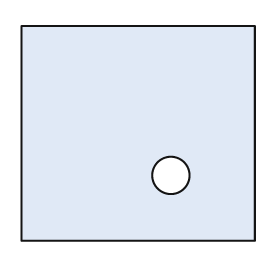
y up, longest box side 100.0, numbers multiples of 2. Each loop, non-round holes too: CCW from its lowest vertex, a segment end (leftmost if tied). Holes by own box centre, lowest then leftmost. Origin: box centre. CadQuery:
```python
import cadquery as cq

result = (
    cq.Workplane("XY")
    .moveTo(-50.0, -46.0)
    .lineTo(50.0, -46.0)
    .lineTo(50.0, 46.0)
    .lineTo(-50.0, 46.0)
    .close()
    .moveTo(14.0, -18.0)
    .circle(8.0)
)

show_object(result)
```